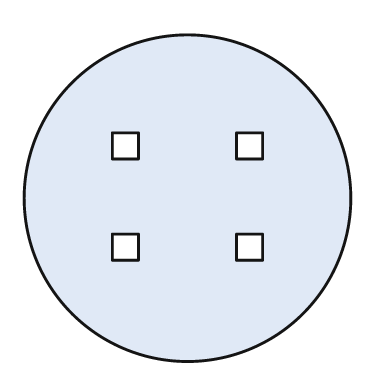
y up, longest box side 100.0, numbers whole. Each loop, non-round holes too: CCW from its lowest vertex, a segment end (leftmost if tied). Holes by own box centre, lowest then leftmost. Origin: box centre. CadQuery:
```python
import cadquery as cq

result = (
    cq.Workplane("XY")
    .moveTo(0.0, 0.0)
    .circle(50.0)
    .moveTo(-23.0, -19.0)
    .lineTo(-15.0, -19.0)
    .lineTo(-15.0, -11.0)
    .lineTo(-23.0, -11.0)
    .close()
    .moveTo(15.0, -19.0)
    .lineTo(23.0, -19.0)
    .lineTo(23.0, -11.0)
    .lineTo(15.0, -11.0)
    .close()
    .moveTo(-23.0, 12.0)
    .lineTo(-15.0, 12.0)
    .lineTo(-15.0, 20.0)
    .lineTo(-23.0, 20.0)
    .close()
    .moveTo(15.0, 12.0)
    .lineTo(23.0, 12.0)
    .lineTo(23.0, 20.0)
    .lineTo(15.0, 20.0)
    .close()
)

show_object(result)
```